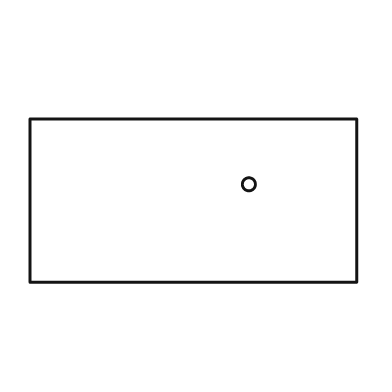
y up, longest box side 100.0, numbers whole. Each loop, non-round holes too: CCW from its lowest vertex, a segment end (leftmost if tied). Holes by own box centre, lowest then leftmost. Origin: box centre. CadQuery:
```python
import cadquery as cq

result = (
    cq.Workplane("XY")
    .moveTo(-50.0, -25.0)
    .lineTo(50.0, -25.0)
    .lineTo(50.0, 25.0)
    .lineTo(-50.0, 25.0)
    .close()
    .moveTo(17.0, 5.0)
    .circle(2.0)
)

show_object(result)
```